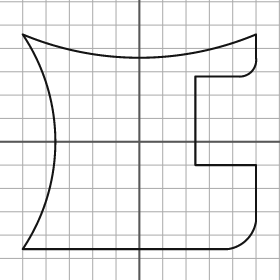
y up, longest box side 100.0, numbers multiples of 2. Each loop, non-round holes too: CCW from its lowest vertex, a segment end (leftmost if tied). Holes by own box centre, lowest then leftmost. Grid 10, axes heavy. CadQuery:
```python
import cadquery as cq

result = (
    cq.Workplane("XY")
    .moveTo(-50.0, -46.0)
    .lineTo(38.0, -46.0)
    .threePointArc((46.0, -42.0), (50.0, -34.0))
    .lineTo(50.0, -10.0)
    .lineTo(24.0, -10.0)
    .lineTo(24.0, 28.0)
    .lineTo(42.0, 28.0)
    .threePointArc((48.0, 30.0), (50.0, 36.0))
    .lineTo(50.0, 46.0)
    .threePointArc((0.0, 36.0), (-50.0, 46.0))
    .threePointArc((-36.0, 0.0), (-50.0, -46.0))
    .close()
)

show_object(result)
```